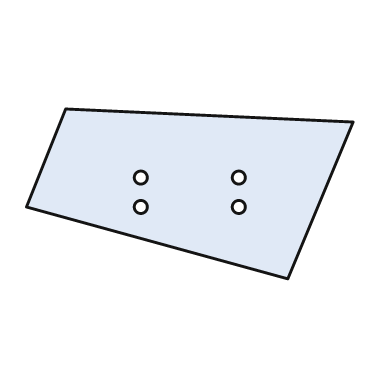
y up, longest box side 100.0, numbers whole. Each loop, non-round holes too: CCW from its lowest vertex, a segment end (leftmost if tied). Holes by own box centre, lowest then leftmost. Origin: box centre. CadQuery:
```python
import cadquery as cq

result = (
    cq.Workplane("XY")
    .moveTo(30.0, -26.0)
    .lineTo(50.0, 22.0)
    .lineTo(-38.0, 26.0)
    .lineTo(-50.0, -4.0)
    .close()
    .moveTo(-15.0, -4.0)
    .circle(2.0)
    .moveTo(15.0, -4.0)
    .circle(2.0)
    .moveTo(-15.0, 5.0)
    .circle(2.0)
    .moveTo(15.0, 5.0)
    .circle(2.0)
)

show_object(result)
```